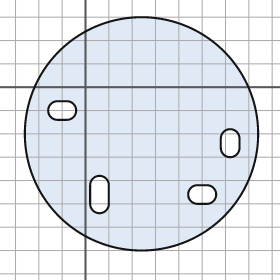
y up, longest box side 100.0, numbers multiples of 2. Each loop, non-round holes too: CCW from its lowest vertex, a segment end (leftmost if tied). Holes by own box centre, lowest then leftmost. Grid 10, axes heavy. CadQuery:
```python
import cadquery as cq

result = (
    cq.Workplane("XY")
    .moveTo(24.0, -20.0)
    .circle(50.0)
    .moveTo(2.0, -50.0)
    .threePointArc((6.0, -54.0), (10.0, -50.0))
    .lineTo(10.0, -42.0)
    .threePointArc((6.0, -38.0), (2.0, -42.0))
    .close()
    .moveTo(48.0, -50.0)
    .lineTo(52.0, -50.0)
    .threePointArc((56.0, -46.0), (52.0, -42.0))
    .lineTo(48.0, -42.0)
    .threePointArc((44.0, -46.0), (48.0, -50.0))
    .close()
    .moveTo(58.0, -26.0)
    .threePointArc((62.0, -30.0), (66.0, -26.0))
    .lineTo(66.0, -22.0)
    .threePointArc((62.0, -18.0), (58.0, -22.0))
    .close()
    .moveTo(-12.0, -14.0)
    .lineTo(-8.0, -14.0)
    .threePointArc((-4.0, -10.0), (-8.0, -6.0))
    .lineTo(-12.0, -6.0)
    .threePointArc((-16.0, -10.0), (-12.0, -14.0))
    .close()
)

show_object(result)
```